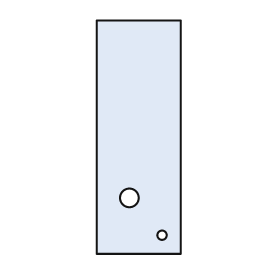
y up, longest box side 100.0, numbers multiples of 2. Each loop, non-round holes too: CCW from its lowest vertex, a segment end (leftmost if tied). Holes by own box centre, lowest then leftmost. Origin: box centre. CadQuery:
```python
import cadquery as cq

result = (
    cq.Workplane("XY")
    .moveTo(-18.0, -50.0)
    .lineTo(18.0, -50.0)
    .lineTo(18.0, 50.0)
    .lineTo(-18.0, 50.0)
    .close()
    .moveTo(10.0, -42.0)
    .circle(2.0)
    .moveTo(-4.0, -26.0)
    .circle(4.0)
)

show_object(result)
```